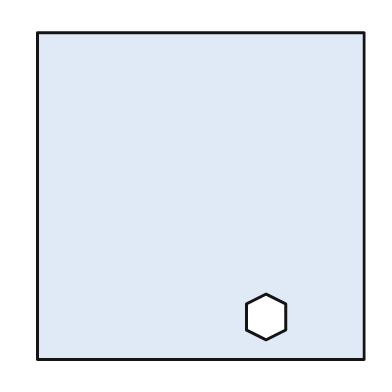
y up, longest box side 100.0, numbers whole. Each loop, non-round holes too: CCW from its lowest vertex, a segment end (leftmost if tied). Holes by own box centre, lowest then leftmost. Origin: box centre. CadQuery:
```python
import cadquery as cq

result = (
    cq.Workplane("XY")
    .moveTo(-50.0, -50.0)
    .lineTo(50.0, -50.0)
    .lineTo(50.0, 50.0)
    .lineTo(-50.0, 50.0)
    .close()
    .moveTo(20.0, -44.0)
    .lineTo(26.0, -41.0)
    .lineTo(26.0, -33.0)
    .lineTo(20.0, -30.0)
    .lineTo(14.0, -33.0)
    .lineTo(14.0, -41.0)
    .close()
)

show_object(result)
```